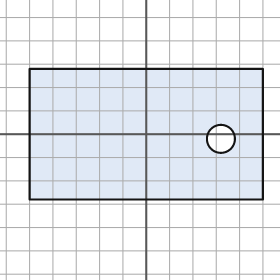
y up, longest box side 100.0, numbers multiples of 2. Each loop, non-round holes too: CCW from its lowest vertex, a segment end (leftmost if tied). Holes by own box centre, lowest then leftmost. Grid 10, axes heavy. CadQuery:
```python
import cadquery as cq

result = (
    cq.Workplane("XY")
    .moveTo(-50.0, -28.0)
    .lineTo(50.0, -28.0)
    .lineTo(50.0, 28.0)
    .lineTo(-50.0, 28.0)
    .close()
    .moveTo(32.0, -2.0)
    .circle(6.0)
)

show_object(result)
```